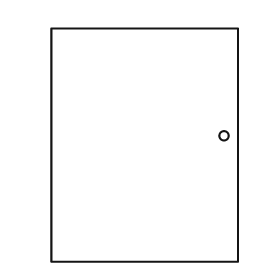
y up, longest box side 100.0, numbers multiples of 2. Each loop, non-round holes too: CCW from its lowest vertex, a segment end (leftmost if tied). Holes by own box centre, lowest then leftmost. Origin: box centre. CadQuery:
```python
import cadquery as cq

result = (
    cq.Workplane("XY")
    .moveTo(-40.0, -50.0)
    .lineTo(40.0, -50.0)
    .lineTo(40.0, 50.0)
    .lineTo(-40.0, 50.0)
    .close()
    .moveTo(34.0, 4.0)
    .circle(2.0)
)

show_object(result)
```